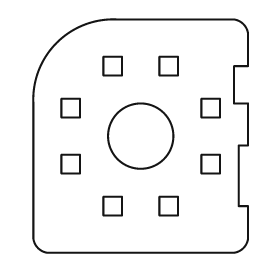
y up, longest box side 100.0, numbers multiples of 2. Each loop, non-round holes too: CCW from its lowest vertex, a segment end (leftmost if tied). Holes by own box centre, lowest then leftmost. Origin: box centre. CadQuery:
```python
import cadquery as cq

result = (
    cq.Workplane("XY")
    .moveTo(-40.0, -50.0)
    .lineTo(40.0, -50.0)
    .threePointArc((44.0, -48.0), (46.0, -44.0))
    .lineTo(46.0, -30.0)
    .lineTo(42.0, -30.0)
    .lineTo(42.0, -4.0)
    .lineTo(46.0, -4.0)
    .lineTo(46.0, 14.0)
    .lineTo(40.0, 14.0)
    .lineTo(40.0, 30.0)
    .lineTo(46.0, 30.0)
    .lineTo(46.0, 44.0)
    .threePointArc((44.0, 48.0), (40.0, 50.0))
    .lineTo(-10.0, 50.0)
    .threePointArc((-36.0, 40.0), (-46.0, 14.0))
    .lineTo(-46.0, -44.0)
    .threePointArc((-44.0, -48.0), (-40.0, -50.0))
    .close()
    .moveTo(-16.0, -34.0)
    .lineTo(-8.0, -34.0)
    .lineTo(-8.0, -26.0)
    .lineTo(-16.0, -26.0)
    .close()
    .moveTo(8.0, -34.0)
    .lineTo(16.0, -34.0)
    .lineTo(16.0, -26.0)
    .lineTo(8.0, -26.0)
    .close()
    .moveTo(-34.0, -16.0)
    .lineTo(-26.0, -16.0)
    .lineTo(-26.0, -8.0)
    .lineTo(-34.0, -8.0)
    .close()
    .moveTo(26.0, -16.0)
    .lineTo(34.0, -16.0)
    .lineTo(34.0, -8.0)
    .lineTo(26.0, -8.0)
    .close()
    .moveTo(0.0, 0.0)
    .circle(14.0)
    .moveTo(-34.0, 8.0)
    .lineTo(-26.0, 8.0)
    .lineTo(-26.0, 16.0)
    .lineTo(-34.0, 16.0)
    .close()
    .moveTo(26.0, 8.0)
    .lineTo(34.0, 8.0)
    .lineTo(34.0, 16.0)
    .lineTo(26.0, 16.0)
    .close()
    .moveTo(-16.0, 26.0)
    .lineTo(-8.0, 26.0)
    .lineTo(-8.0, 34.0)
    .lineTo(-16.0, 34.0)
    .close()
    .moveTo(8.0, 26.0)
    .lineTo(16.0, 26.0)
    .lineTo(16.0, 34.0)
    .lineTo(8.0, 34.0)
    .close()
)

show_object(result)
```